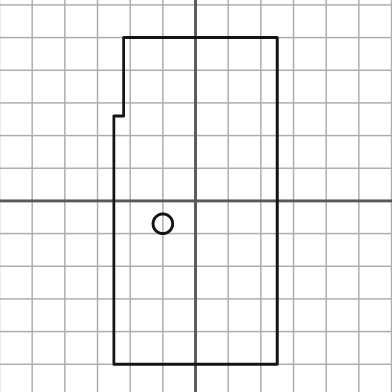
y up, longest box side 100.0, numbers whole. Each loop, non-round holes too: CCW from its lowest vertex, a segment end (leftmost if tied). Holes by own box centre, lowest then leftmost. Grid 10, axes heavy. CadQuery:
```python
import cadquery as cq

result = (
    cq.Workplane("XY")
    .moveTo(-25.0, -50.0)
    .lineTo(25.0, -50.0)
    .lineTo(25.0, 50.0)
    .lineTo(-22.0, 50.0)
    .lineTo(-22.0, 26.0)
    .lineTo(-25.0, 26.0)
    .close()
    .moveTo(-10.0, -7.0)
    .circle(3.0)
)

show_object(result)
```